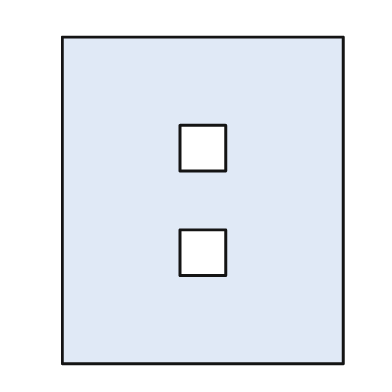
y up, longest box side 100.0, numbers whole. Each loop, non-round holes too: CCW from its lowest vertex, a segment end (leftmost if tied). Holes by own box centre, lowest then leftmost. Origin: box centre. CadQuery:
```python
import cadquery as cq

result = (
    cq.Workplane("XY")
    .moveTo(-43.0, -50.0)
    .lineTo(43.0, -50.0)
    .lineTo(43.0, 50.0)
    .lineTo(-43.0, 50.0)
    .close()
    .moveTo(-7.0, -23.0)
    .lineTo(7.0, -23.0)
    .lineTo(7.0, -9.0)
    .lineTo(-7.0, -9.0)
    .close()
    .moveTo(-7.0, 9.0)
    .lineTo(7.0, 9.0)
    .lineTo(7.0, 23.0)
    .lineTo(-7.0, 23.0)
    .close()
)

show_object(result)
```